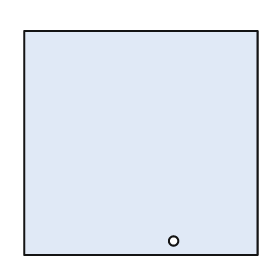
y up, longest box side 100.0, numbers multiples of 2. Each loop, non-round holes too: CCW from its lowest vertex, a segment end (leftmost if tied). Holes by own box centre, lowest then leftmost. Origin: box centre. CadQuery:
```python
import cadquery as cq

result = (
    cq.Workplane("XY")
    .moveTo(-50.0, -48.0)
    .lineTo(50.0, -48.0)
    .lineTo(50.0, 48.0)
    .lineTo(-50.0, 48.0)
    .close()
    .moveTo(14.0, -42.0)
    .circle(2.0)
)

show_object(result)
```